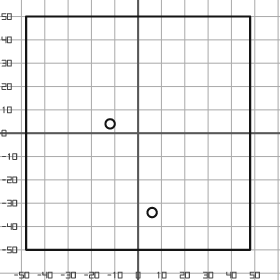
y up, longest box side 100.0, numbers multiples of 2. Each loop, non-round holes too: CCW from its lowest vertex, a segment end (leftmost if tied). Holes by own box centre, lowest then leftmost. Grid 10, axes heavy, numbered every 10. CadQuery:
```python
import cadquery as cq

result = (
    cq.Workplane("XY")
    .moveTo(-48.0, -50.0)
    .lineTo(48.0, -50.0)
    .lineTo(48.0, 50.0)
    .lineTo(-48.0, 50.0)
    .close()
    .moveTo(6.0, -34.0)
    .circle(2.0)
    .moveTo(-12.0, 4.0)
    .circle(2.0)
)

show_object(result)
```